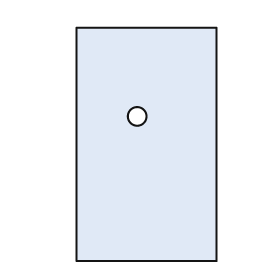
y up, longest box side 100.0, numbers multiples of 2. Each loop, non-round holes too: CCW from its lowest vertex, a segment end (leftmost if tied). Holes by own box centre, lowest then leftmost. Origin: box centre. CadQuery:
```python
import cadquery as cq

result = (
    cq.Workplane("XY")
    .moveTo(-30.0, -50.0)
    .lineTo(30.0, -50.0)
    .lineTo(30.0, 50.0)
    .lineTo(-30.0, 50.0)
    .close()
    .moveTo(-4.0, 12.0)
    .circle(4.0)
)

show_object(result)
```